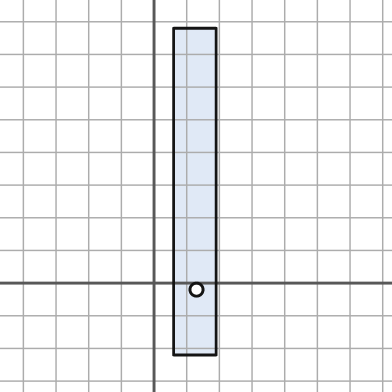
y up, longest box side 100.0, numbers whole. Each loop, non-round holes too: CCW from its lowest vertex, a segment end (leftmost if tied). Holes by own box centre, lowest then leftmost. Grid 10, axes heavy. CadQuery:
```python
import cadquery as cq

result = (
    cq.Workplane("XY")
    .moveTo(6.0, -22.0)
    .lineTo(19.0, -22.0)
    .lineTo(19.0, 78.0)
    .lineTo(6.0, 78.0)
    .close()
    .moveTo(13.0, -2.0)
    .circle(2.0)
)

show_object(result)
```